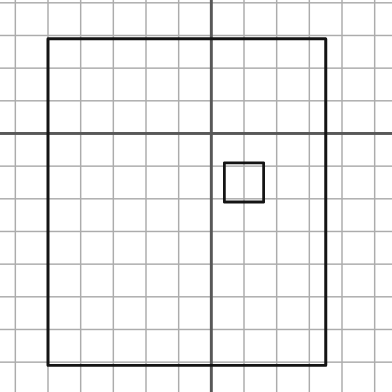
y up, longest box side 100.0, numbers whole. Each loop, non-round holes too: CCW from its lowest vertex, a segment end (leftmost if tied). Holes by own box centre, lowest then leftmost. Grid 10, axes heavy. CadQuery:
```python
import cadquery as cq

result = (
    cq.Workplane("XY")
    .moveTo(-50.0, -71.0)
    .lineTo(35.0, -71.0)
    .lineTo(35.0, 29.0)
    .lineTo(-50.0, 29.0)
    .close()
    .moveTo(4.0, -21.0)
    .lineTo(16.0, -21.0)
    .lineTo(16.0, -9.0)
    .lineTo(4.0, -9.0)
    .close()
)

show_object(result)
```